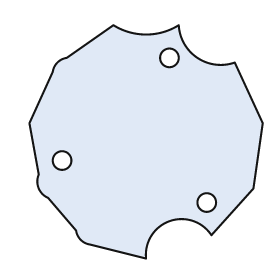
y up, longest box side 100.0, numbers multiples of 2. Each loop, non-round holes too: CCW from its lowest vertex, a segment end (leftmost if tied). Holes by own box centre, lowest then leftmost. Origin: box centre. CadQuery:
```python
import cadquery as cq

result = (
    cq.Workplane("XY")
    .moveTo(0.0, -50.0)
    .threePointArc((10.0, -34.0), (28.0, -40.0))
    .lineTo(46.0, -20.0)
    .lineTo(50.0, 8.0)
    .lineTo(38.0, 34.0)
    .threePointArc((22.0, 36.0), (14.0, 50.0))
    .threePointArc((0.0, 46.0), (-14.0, 50.0))
    .lineTo(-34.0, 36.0)
    .threePointArc((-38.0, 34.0), (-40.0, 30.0))
    .lineTo(-50.0, 8.0)
    .lineTo(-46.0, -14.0)
    .threePointArc((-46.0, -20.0), (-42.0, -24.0))
    .lineTo(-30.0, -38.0)
    .threePointArc((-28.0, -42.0), (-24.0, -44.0))
    .close()
    .moveTo(26.0, -26.0)
    .circle(4.0)
    .moveTo(-36.0, -8.0)
    .circle(4.0)
    .moveTo(10.0, 36.0)
    .circle(4.0)
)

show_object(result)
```